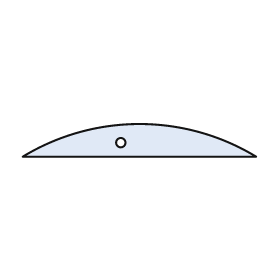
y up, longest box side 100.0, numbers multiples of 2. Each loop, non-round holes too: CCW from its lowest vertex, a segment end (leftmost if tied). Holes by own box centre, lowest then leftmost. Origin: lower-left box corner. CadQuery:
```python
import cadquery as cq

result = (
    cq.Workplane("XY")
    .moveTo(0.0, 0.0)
    .lineTo(100.0, 0.0)
    .threePointArc((50.0, 14.0), (0.0, 0.0))
    .close()
    .moveTo(42.0, 6.0)
    .circle(2.0)
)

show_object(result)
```